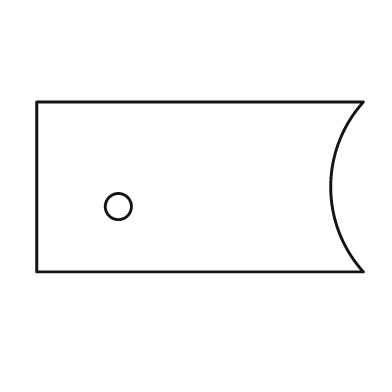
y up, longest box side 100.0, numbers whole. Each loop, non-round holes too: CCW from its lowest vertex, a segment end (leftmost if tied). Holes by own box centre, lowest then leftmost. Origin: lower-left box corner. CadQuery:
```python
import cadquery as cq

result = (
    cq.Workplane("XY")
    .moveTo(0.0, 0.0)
    .lineTo(100.0, 0.0)
    .threePointArc((90.0, 26.0), (100.0, 52.0))
    .lineTo(0.0, 52.0)
    .close()
    .moveTo(25.0, 20.0)
    .circle(4.0)
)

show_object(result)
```